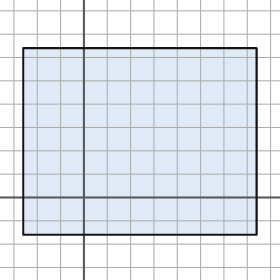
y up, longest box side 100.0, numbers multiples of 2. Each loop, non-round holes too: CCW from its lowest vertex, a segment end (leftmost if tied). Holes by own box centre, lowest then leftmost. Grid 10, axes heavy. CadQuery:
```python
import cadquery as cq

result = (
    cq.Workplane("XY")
    .moveTo(-26.0, -16.0)
    .lineTo(74.0, -16.0)
    .lineTo(74.0, 64.0)
    .lineTo(-26.0, 64.0)
    .close()
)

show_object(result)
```